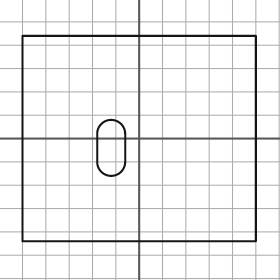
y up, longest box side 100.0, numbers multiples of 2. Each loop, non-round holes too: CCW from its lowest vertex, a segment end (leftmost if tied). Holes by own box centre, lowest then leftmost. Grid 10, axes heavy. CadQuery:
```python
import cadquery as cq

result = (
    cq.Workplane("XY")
    .moveTo(-50.0, -44.0)
    .lineTo(50.0, -44.0)
    .lineTo(50.0, 44.0)
    .lineTo(-50.0, 44.0)
    .close()
    .moveTo(-18.0, -10.0)
    .threePointArc((-12.0, -16.0), (-6.0, -10.0))
    .lineTo(-6.0, 2.0)
    .threePointArc((-12.0, 8.0), (-18.0, 2.0))
    .close()
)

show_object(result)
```